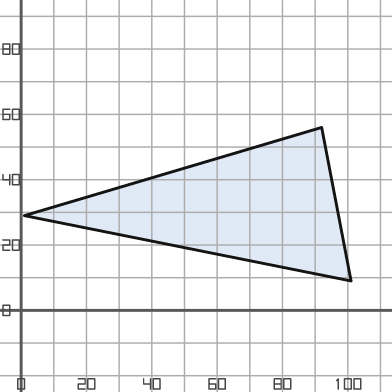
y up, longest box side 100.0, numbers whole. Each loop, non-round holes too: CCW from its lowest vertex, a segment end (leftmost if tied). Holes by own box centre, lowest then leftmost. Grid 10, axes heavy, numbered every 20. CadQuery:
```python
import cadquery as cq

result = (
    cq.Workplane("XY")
    .moveTo(101.0, 9.0)
    .lineTo(92.0, 56.0)
    .lineTo(1.0, 29.0)
    .close()
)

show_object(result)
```